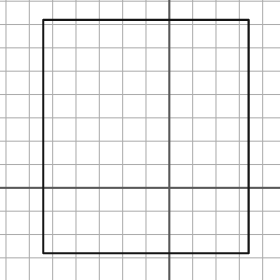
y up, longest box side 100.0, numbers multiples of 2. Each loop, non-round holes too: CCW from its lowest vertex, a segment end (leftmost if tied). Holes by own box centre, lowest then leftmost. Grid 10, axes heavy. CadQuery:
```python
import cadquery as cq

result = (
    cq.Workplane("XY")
    .moveTo(-54.0, -28.0)
    .lineTo(34.0, -28.0)
    .lineTo(34.0, 72.0)
    .lineTo(-54.0, 72.0)
    .close()
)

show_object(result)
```